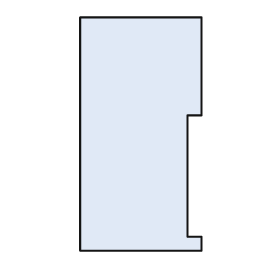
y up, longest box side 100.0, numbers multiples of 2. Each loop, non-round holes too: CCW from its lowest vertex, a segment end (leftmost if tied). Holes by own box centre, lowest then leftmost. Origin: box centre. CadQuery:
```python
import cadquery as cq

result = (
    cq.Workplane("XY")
    .moveTo(-26.0, -50.0)
    .lineTo(26.0, -50.0)
    .lineTo(26.0, -44.0)
    .lineTo(20.0, -44.0)
    .lineTo(20.0, 8.0)
    .lineTo(26.0, 8.0)
    .lineTo(26.0, 50.0)
    .lineTo(-26.0, 50.0)
    .close()
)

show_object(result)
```